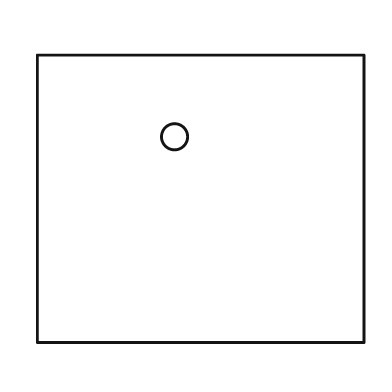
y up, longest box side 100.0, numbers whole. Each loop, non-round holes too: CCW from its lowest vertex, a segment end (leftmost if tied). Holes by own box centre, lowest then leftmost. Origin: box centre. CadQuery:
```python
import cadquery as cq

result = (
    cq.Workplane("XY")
    .moveTo(-50.0, -44.0)
    .lineTo(50.0, -44.0)
    .lineTo(50.0, 44.0)
    .lineTo(-50.0, 44.0)
    .close()
    .moveTo(-8.0, 19.0)
    .circle(4.0)
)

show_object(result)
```